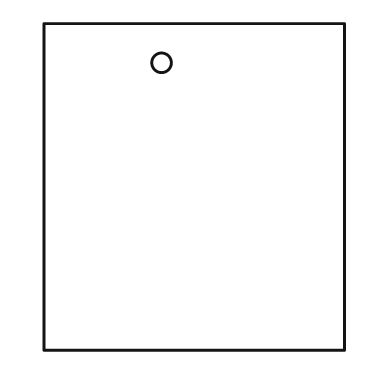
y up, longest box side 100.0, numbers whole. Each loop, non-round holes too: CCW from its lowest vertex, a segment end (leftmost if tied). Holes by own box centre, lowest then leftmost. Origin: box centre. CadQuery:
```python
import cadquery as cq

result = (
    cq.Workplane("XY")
    .moveTo(-46.0, -50.0)
    .lineTo(46.0, -50.0)
    .lineTo(46.0, 50.0)
    .lineTo(-46.0, 50.0)
    .close()
    .moveTo(-10.0, 38.0)
    .circle(3.0)
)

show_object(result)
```